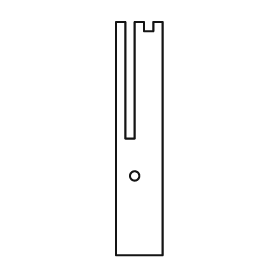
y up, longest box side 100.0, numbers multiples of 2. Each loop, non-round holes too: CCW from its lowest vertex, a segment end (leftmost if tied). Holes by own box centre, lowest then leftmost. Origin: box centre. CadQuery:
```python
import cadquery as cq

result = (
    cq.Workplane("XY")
    .moveTo(-10.0, -50.0)
    .lineTo(10.0, -50.0)
    .lineTo(10.0, 50.0)
    .lineTo(6.0, 50.0)
    .lineTo(6.0, 46.0)
    .lineTo(2.0, 46.0)
    .lineTo(2.0, 50.0)
    .lineTo(-2.0, 50.0)
    .lineTo(-2.0, 0.0)
    .lineTo(-6.0, 0.0)
    .lineTo(-6.0, 50.0)
    .lineTo(-10.0, 50.0)
    .close()
    .moveTo(-2.0, -16.0)
    .circle(2.0)
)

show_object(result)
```